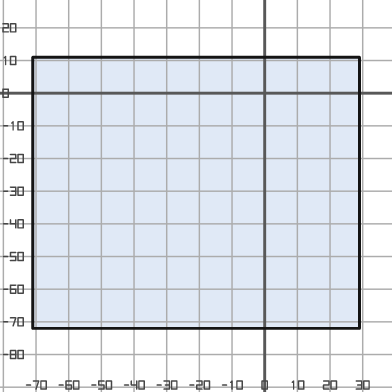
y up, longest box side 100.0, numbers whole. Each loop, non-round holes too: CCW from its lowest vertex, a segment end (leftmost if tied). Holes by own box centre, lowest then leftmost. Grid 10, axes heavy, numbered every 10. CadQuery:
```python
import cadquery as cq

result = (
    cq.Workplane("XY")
    .moveTo(-71.0, -72.0)
    .lineTo(29.0, -72.0)
    .lineTo(29.0, 11.0)
    .lineTo(-71.0, 11.0)
    .close()
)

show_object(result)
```